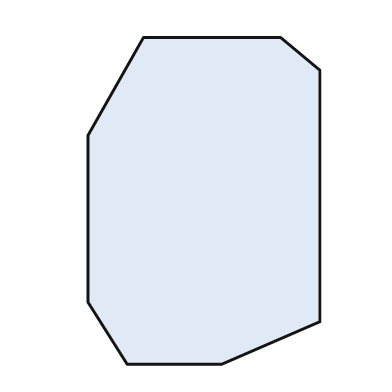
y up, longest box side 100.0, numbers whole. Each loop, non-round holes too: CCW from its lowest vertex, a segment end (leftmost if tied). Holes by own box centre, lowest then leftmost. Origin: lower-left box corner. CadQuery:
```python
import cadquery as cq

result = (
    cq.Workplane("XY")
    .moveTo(12.0, 0.0)
    .lineTo(41.0, 0.0)
    .lineTo(71.0, 13.0)
    .lineTo(71.0, 90.0)
    .lineTo(59.0, 100.0)
    .lineTo(17.0, 100.0)
    .lineTo(0.0, 70.0)
    .lineTo(0.0, 19.0)
    .close()
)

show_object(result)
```